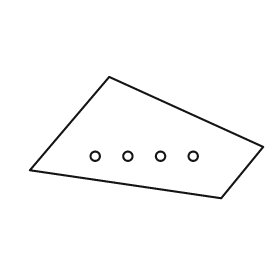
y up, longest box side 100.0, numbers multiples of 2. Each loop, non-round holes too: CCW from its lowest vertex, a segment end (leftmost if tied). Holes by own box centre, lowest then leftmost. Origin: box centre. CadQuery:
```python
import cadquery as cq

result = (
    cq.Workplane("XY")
    .moveTo(32.0, -26.0)
    .lineTo(50.0, -4.0)
    .lineTo(-16.0, 26.0)
    .lineTo(-50.0, -14.0)
    .close()
    .moveTo(-22.0, -8.0)
    .circle(2.0)
    .moveTo(-8.0, -8.0)
    .circle(2.0)
    .moveTo(6.0, -8.0)
    .circle(2.0)
    .moveTo(20.0, -8.0)
    .circle(2.0)
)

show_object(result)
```